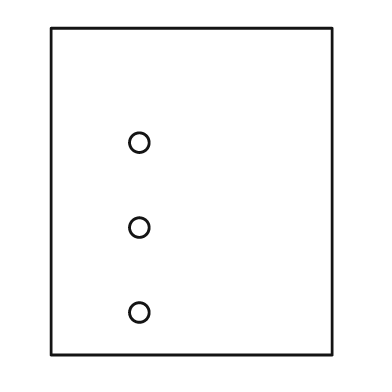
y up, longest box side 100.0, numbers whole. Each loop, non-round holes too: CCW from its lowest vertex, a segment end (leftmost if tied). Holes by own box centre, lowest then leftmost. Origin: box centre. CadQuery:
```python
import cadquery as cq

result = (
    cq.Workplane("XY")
    .moveTo(-43.0, -50.0)
    .lineTo(43.0, -50.0)
    .lineTo(43.0, 50.0)
    .lineTo(-43.0, 50.0)
    .close()
    .moveTo(-16.0, -37.0)
    .circle(3.0)
    .moveTo(-16.0, -11.0)
    .circle(3.0)
    .moveTo(-16.0, 15.0)
    .circle(3.0)
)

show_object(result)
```